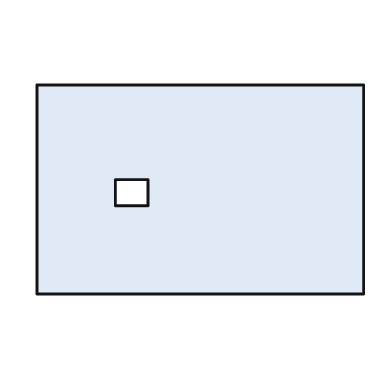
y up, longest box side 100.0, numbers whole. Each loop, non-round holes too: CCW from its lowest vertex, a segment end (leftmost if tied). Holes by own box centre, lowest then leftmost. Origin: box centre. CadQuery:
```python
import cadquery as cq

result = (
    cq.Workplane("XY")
    .moveTo(-50.0, -32.0)
    .lineTo(50.0, -32.0)
    .lineTo(50.0, 32.0)
    .lineTo(-50.0, 32.0)
    .close()
    .moveTo(-26.0, -5.0)
    .lineTo(-16.0, -5.0)
    .lineTo(-16.0, 3.0)
    .lineTo(-26.0, 3.0)
    .close()
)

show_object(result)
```